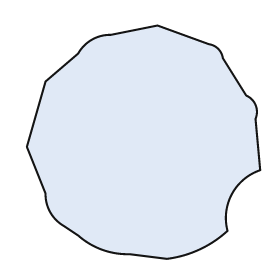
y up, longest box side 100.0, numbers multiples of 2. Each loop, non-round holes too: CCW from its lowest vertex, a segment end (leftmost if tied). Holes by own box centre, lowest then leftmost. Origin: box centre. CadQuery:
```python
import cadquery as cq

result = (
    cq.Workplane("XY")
    .moveTo(10.0, -50.0)
    .threePointArc((24.0, -46.0), (36.0, -38.0))
    .threePointArc((38.0, -22.0), (50.0, -12.0))
    .lineTo(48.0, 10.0)
    .threePointArc((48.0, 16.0), (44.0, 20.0))
    .lineTo(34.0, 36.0)
    .threePointArc((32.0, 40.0), (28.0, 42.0))
    .lineTo(6.0, 50.0)
    .lineTo(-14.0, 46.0)
    .threePointArc((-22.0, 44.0), (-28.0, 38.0))
    .lineTo(-42.0, 26.0)
    .lineTo(-50.0, -2.0)
    .lineTo(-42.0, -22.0)
    .threePointArc((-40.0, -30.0), (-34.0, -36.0))
    .lineTo(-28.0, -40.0)
    .threePointArc((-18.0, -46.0), (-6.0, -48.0))
    .close()
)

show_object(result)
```